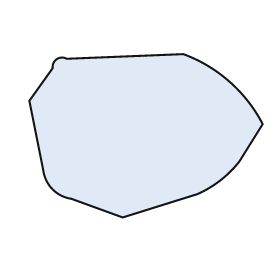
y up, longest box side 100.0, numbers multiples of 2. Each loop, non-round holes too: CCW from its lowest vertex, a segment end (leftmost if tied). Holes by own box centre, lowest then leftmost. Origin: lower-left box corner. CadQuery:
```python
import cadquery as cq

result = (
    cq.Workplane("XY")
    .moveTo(40.0, 0.0)
    .lineTo(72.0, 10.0)
    .threePointArc((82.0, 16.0), (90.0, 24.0))
    .lineTo(100.0, 40.0)
    .threePointArc((86.0, 58.0), (66.0, 70.0))
    .lineTo(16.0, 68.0)
    .threePointArc((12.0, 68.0), (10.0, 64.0))
    .lineTo(0.0, 50.0)
    .lineTo(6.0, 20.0)
    .threePointArc((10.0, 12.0), (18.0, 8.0))
    .close()
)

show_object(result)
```